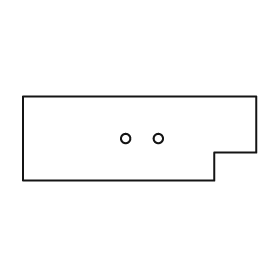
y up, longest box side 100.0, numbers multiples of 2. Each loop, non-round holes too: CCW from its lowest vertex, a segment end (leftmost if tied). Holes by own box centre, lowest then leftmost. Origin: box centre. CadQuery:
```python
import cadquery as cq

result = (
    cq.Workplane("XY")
    .moveTo(-50.0, -18.0)
    .lineTo(32.0, -18.0)
    .lineTo(32.0, -6.0)
    .lineTo(50.0, -6.0)
    .lineTo(50.0, 18.0)
    .lineTo(-50.0, 18.0)
    .close()
    .moveTo(-6.0, 0.0)
    .circle(2.0)
    .moveTo(8.0, 0.0)
    .circle(2.0)
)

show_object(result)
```